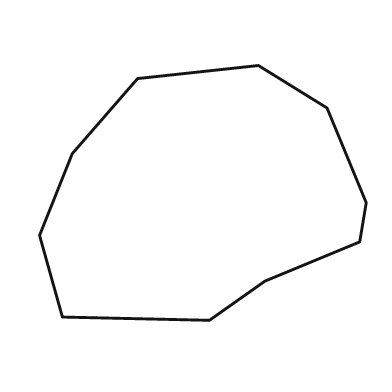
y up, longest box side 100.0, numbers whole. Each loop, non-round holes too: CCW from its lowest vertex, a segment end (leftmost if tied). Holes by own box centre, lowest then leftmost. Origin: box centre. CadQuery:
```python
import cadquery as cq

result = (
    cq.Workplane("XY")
    .moveTo(2.0, -39.0)
    .lineTo(19.0, -27.0)
    .lineTo(48.0, -15.0)
    .lineTo(50.0, -3.0)
    .lineTo(38.0, 26.0)
    .lineTo(17.0, 39.0)
    .lineTo(-20.0, 35.0)
    .lineTo(-40.0, 12.0)
    .lineTo(-50.0, -13.0)
    .lineTo(-43.0, -38.0)
    .close()
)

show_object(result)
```